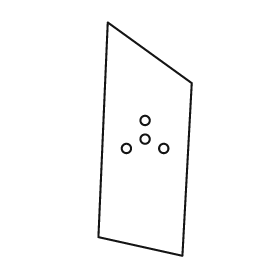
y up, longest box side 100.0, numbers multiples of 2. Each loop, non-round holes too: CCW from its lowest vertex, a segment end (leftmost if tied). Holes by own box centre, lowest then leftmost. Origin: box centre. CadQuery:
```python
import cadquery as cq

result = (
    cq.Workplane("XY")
    .moveTo(16.0, -50.0)
    .lineTo(20.0, 24.0)
    .lineTo(-16.0, 50.0)
    .lineTo(-20.0, -42.0)
    .close()
    .moveTo(-8.0, -4.0)
    .circle(2.0)
    .moveTo(8.0, -4.0)
    .circle(2.0)
    .moveTo(0.0, 0.0)
    .circle(2.0)
    .moveTo(0.0, 8.0)
    .circle(2.0)
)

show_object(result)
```